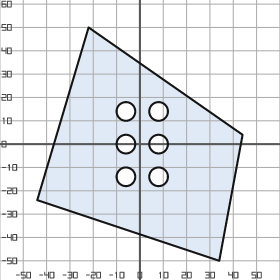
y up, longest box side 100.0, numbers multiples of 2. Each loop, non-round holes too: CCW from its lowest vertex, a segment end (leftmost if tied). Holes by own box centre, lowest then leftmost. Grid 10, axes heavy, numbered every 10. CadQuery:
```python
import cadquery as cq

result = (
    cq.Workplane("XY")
    .moveTo(34.0, -50.0)
    .lineTo(44.0, 4.0)
    .lineTo(-22.0, 50.0)
    .lineTo(-44.0, -24.0)
    .close()
    .moveTo(-6.0, -14.0)
    .circle(4.0)
    .moveTo(8.0, -14.0)
    .circle(4.0)
    .moveTo(-6.0, 0.0)
    .circle(4.0)
    .moveTo(8.0, 0.0)
    .circle(4.0)
    .moveTo(-6.0, 14.0)
    .circle(4.0)
    .moveTo(8.0, 14.0)
    .circle(4.0)
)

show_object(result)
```